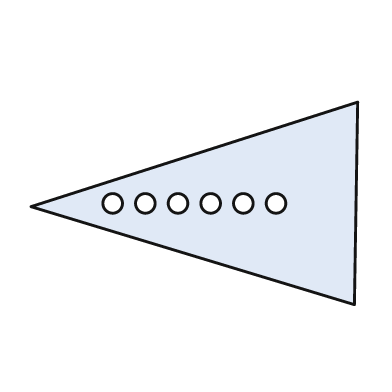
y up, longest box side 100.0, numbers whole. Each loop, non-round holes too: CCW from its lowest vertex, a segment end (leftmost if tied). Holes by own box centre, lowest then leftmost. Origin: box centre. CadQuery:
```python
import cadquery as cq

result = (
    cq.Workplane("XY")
    .moveTo(49.0, -31.0)
    .lineTo(50.0, 31.0)
    .lineTo(-50.0, -1.0)
    .close()
    .moveTo(-25.0, 0.0)
    .circle(3.0)
    .moveTo(-15.0, 0.0)
    .circle(3.0)
    .moveTo(-5.0, 0.0)
    .circle(3.0)
    .moveTo(5.0, 0.0)
    .circle(3.0)
    .moveTo(15.0, 0.0)
    .circle(3.0)
    .moveTo(25.0, 0.0)
    .circle(3.0)
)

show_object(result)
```